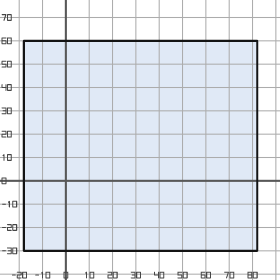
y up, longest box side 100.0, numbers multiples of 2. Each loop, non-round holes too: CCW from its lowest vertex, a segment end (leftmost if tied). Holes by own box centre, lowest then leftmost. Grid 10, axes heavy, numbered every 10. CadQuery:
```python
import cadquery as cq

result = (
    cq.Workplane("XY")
    .moveTo(-18.0, -30.0)
    .lineTo(82.0, -30.0)
    .lineTo(82.0, 60.0)
    .lineTo(-18.0, 60.0)
    .close()
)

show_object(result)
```